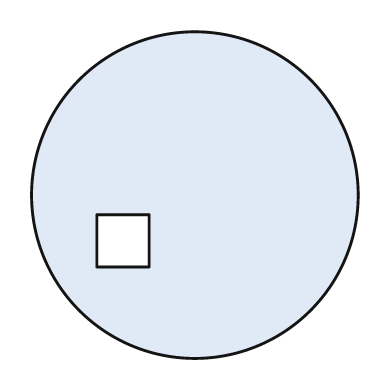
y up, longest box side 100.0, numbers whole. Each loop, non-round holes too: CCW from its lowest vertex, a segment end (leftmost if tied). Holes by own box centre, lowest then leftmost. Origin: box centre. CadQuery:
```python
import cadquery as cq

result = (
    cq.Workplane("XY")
    .moveTo(0.0, 0.0)
    .circle(50.0)
    .moveTo(-30.0, -22.0)
    .lineTo(-14.0, -22.0)
    .lineTo(-14.0, -6.0)
    .lineTo(-30.0, -6.0)
    .close()
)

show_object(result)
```